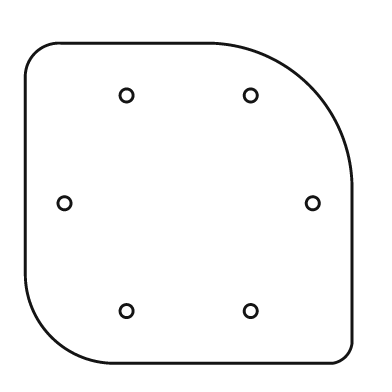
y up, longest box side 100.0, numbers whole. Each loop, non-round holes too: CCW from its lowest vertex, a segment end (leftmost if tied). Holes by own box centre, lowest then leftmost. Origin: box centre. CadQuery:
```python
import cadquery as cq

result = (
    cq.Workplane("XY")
    .moveTo(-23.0, -49.0)
    .lineTo(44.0, -49.0)
    .threePointArc((48.0, -47.0), (50.0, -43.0))
    .lineTo(50.0, 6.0)
    .threePointArc((37.0, 36.0), (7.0, 49.0))
    .lineTo(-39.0, 49.0)
    .threePointArc((-47.0, 46.0), (-50.0, 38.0))
    .lineTo(-50.0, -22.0)
    .threePointArc((-42.0, -41.0), (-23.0, -49.0))
    .close()
    .moveTo(-19.0, -33.0)
    .circle(2.0)
    .moveTo(19.0, -33.0)
    .circle(2.0)
    .moveTo(-38.0, 0.0)
    .circle(2.0)
    .moveTo(38.0, 0.0)
    .circle(2.0)
    .moveTo(-19.0, 33.0)
    .circle(2.0)
    .moveTo(19.0, 33.0)
    .circle(2.0)
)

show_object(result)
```